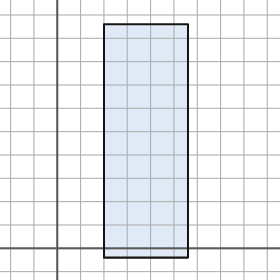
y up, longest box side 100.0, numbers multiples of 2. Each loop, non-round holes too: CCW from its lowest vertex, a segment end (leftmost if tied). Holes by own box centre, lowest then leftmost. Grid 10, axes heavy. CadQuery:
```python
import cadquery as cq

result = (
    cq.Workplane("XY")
    .moveTo(20.0, -4.0)
    .lineTo(56.0, -4.0)
    .lineTo(56.0, 96.0)
    .lineTo(20.0, 96.0)
    .close()
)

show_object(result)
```